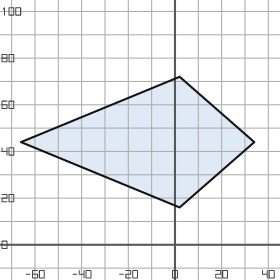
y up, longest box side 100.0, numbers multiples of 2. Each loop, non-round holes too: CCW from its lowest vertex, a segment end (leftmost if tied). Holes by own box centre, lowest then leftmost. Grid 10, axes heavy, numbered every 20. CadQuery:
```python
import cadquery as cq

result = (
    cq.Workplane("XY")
    .moveTo(2.0, 16.0)
    .lineTo(34.0, 44.0)
    .lineTo(2.0, 72.0)
    .lineTo(-66.0, 44.0)
    .close()
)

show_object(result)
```